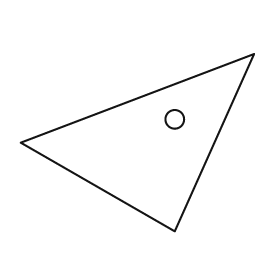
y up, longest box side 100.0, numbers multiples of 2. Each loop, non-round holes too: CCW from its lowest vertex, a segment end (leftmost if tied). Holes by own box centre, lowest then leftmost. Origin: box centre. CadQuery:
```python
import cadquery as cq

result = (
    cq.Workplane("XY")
    .moveTo(16.0, -38.0)
    .lineTo(50.0, 38.0)
    .lineTo(-50.0, 0.0)
    .close()
    .moveTo(16.0, 10.0)
    .circle(4.0)
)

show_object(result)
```